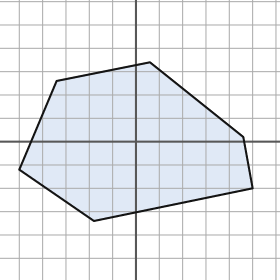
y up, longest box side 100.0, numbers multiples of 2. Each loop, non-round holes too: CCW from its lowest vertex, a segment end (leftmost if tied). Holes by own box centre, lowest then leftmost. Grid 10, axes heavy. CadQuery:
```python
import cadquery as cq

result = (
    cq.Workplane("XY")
    .moveTo(-18.0, -34.0)
    .lineTo(50.0, -20.0)
    .lineTo(46.0, 2.0)
    .lineTo(6.0, 34.0)
    .lineTo(-34.0, 26.0)
    .lineTo(-50.0, -12.0)
    .close()
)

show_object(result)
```